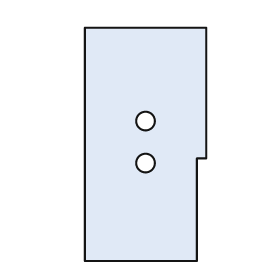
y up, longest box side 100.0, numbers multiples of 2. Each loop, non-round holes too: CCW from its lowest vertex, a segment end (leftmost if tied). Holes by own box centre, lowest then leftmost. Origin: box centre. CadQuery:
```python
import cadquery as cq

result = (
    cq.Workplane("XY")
    .moveTo(-26.0, -50.0)
    .lineTo(22.0, -50.0)
    .lineTo(22.0, -6.0)
    .lineTo(26.0, -6.0)
    .lineTo(26.0, 50.0)
    .lineTo(-26.0, 50.0)
    .close()
    .moveTo(0.0, -8.0)
    .circle(4.0)
    .moveTo(0.0, 10.0)
    .circle(4.0)
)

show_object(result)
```